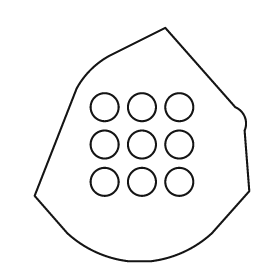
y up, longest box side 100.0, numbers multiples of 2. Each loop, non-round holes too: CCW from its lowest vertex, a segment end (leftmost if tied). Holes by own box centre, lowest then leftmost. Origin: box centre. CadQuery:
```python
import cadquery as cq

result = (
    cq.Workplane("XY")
    .moveTo(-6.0, -50.0)
    .lineTo(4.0, -50.0)
    .threePointArc((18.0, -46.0), (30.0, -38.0))
    .lineTo(46.0, -20.0)
    .lineTo(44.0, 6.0)
    .threePointArc((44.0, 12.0), (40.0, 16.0))
    .lineTo(10.0, 50.0)
    .lineTo(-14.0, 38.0)
    .threePointArc((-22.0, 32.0), (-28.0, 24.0))
    .lineTo(-46.0, -22.0)
    .lineTo(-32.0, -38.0)
    .threePointArc((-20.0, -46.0), (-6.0, -50.0))
    .close()
    .moveTo(-16.0, -16.0)
    .circle(6.0)
    .moveTo(0.0, -16.0)
    .circle(6.0)
    .moveTo(16.0, -16.0)
    .circle(6.0)
    .moveTo(-16.0, 0.0)
    .circle(6.0)
    .moveTo(0.0, 0.0)
    .circle(6.0)
    .moveTo(16.0, 0.0)
    .circle(6.0)
    .moveTo(-16.0, 16.0)
    .circle(6.0)
    .moveTo(0.0, 16.0)
    .circle(6.0)
    .moveTo(16.0, 16.0)
    .circle(6.0)
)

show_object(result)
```